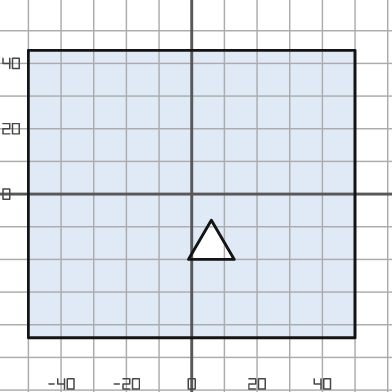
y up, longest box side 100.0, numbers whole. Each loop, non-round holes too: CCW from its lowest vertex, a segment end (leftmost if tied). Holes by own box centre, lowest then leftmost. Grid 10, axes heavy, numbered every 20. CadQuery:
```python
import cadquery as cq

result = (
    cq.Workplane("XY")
    .moveTo(-50.0, -44.0)
    .lineTo(50.0, -44.0)
    .lineTo(50.0, 44.0)
    .lineTo(-50.0, 44.0)
    .close()
    .moveTo(-1.0, -20.0)
    .lineTo(13.0, -20.0)
    .lineTo(6.0, -8.0)
    .close()
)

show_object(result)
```